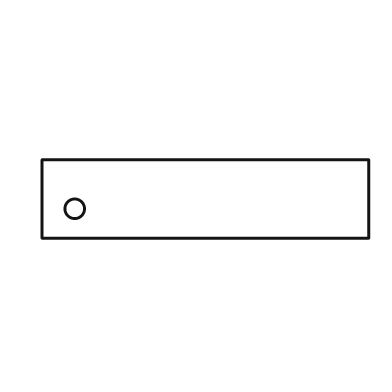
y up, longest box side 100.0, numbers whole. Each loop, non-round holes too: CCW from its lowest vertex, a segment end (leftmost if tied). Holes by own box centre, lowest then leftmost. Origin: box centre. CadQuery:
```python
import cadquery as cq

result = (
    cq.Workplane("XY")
    .moveTo(-50.0, -12.0)
    .lineTo(50.0, -12.0)
    .lineTo(50.0, 12.0)
    .lineTo(-50.0, 12.0)
    .close()
    .moveTo(-40.0, -3.0)
    .circle(3.0)
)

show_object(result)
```